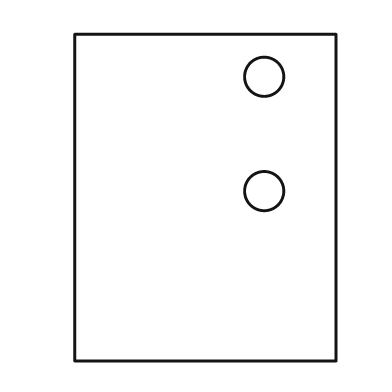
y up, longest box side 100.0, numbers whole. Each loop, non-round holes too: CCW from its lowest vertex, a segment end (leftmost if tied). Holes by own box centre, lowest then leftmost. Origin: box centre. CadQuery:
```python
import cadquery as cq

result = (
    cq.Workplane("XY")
    .moveTo(-40.0, -50.0)
    .lineTo(40.0, -50.0)
    .lineTo(40.0, 50.0)
    .lineTo(-40.0, 50.0)
    .close()
    .moveTo(18.0, 2.0)
    .circle(6.0)
    .moveTo(18.0, 37.0)
    .circle(6.0)
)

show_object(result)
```